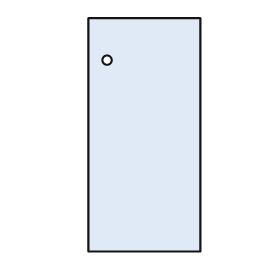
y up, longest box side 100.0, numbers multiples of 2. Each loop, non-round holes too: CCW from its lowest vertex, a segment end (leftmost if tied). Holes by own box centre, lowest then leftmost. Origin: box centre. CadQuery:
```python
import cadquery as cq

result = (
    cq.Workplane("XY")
    .moveTo(-24.0, -50.0)
    .lineTo(24.0, -50.0)
    .lineTo(24.0, 50.0)
    .lineTo(-24.0, 50.0)
    .close()
    .moveTo(-16.0, 32.0)
    .circle(2.0)
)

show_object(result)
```